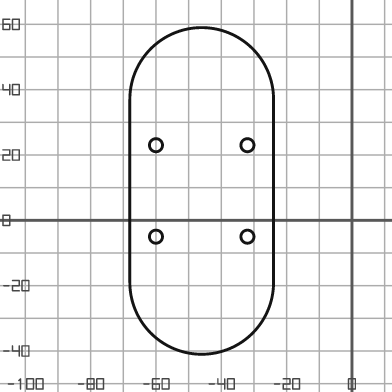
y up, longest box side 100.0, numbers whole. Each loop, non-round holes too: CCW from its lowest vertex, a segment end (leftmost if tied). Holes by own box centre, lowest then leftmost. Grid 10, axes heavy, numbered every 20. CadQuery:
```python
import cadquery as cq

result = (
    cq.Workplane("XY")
    .moveTo(-68.0, -19.0)
    .threePointArc((-46.0, -41.0), (-24.0, -19.0))
    .lineTo(-24.0, 37.0)
    .threePointArc((-46.0, 59.0), (-68.0, 37.0))
    .close()
    .moveTo(-60.0, -5.0)
    .circle(2.0)
    .moveTo(-32.0, -5.0)
    .circle(2.0)
    .moveTo(-60.0, 23.0)
    .circle(2.0)
    .moveTo(-32.0, 23.0)
    .circle(2.0)
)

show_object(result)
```